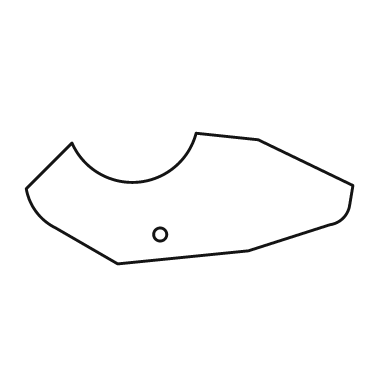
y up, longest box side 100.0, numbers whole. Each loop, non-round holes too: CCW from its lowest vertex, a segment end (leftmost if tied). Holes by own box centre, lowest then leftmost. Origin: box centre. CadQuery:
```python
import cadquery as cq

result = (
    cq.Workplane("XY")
    .moveTo(-22.0, -20.0)
    .lineTo(18.0, -16.0)
    .lineTo(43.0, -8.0)
    .threePointArc((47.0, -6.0), (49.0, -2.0))
    .lineTo(50.0, 4.0)
    .lineTo(21.0, 18.0)
    .lineTo(2.0, 20.0)
    .threePointArc((-16.0, 5.0), (-36.0, 17.0))
    .lineTo(-50.0, 3.0)
    .threePointArc((-47.0, -4.0), (-41.0, -9.0))
    .close()
    .moveTo(-9.0, -11.0)
    .circle(2.0)
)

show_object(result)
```